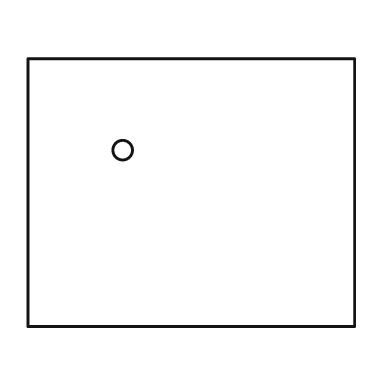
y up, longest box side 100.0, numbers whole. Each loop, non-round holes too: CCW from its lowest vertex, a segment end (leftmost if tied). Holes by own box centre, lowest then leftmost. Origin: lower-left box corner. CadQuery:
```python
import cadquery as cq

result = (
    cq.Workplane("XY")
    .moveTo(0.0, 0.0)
    .lineTo(100.0, 0.0)
    .lineTo(100.0, 82.0)
    .lineTo(0.0, 82.0)
    .close()
    .moveTo(29.0, 54.0)
    .circle(3.0)
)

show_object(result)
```